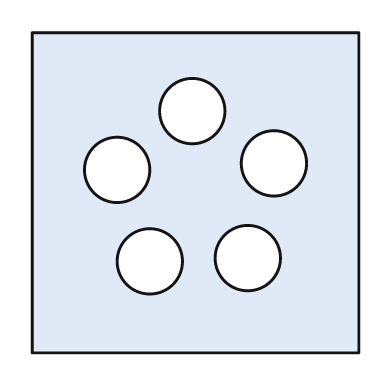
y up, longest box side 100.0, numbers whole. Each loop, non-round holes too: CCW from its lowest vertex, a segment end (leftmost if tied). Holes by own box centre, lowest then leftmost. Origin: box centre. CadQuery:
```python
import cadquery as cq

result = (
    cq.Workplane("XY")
    .moveTo(-50.0, -49.0)
    .lineTo(50.0, -49.0)
    .lineTo(50.0, 49.0)
    .lineTo(-50.0, 49.0)
    .close()
    .moveTo(-14.0, -21.0)
    .circle(10.0)
    .moveTo(16.0, -20.0)
    .circle(10.0)
    .moveTo(-24.0, 7.0)
    .circle(10.0)
    .moveTo(24.0, 9.0)
    .circle(10.0)
    .moveTo(-1.0, 25.0)
    .circle(10.0)
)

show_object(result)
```